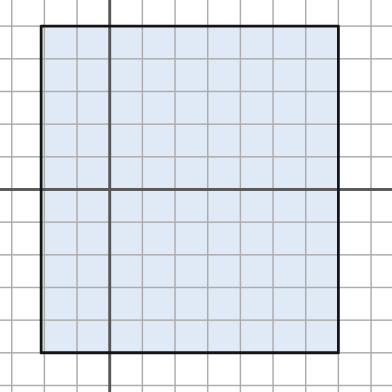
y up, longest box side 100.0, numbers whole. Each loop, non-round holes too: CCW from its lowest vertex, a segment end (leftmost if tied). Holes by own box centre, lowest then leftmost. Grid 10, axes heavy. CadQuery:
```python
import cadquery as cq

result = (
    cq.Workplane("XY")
    .moveTo(-21.0, -50.0)
    .lineTo(70.0, -50.0)
    .lineTo(70.0, 50.0)
    .lineTo(-21.0, 50.0)
    .close()
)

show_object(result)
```